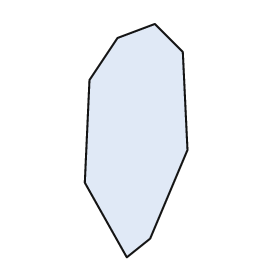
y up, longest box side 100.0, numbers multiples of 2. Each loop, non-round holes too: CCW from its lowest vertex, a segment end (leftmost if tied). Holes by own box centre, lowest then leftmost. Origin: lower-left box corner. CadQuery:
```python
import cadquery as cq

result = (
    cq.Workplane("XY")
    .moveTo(18.0, 0.0)
    .lineTo(28.0, 8.0)
    .lineTo(44.0, 46.0)
    .lineTo(42.0, 88.0)
    .lineTo(30.0, 100.0)
    .lineTo(14.0, 94.0)
    .lineTo(2.0, 76.0)
    .lineTo(0.0, 32.0)
    .close()
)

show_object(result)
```